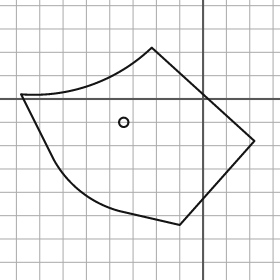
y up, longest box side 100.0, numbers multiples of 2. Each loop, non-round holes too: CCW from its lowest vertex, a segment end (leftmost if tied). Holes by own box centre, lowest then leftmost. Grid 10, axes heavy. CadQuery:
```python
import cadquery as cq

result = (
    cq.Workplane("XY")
    .moveTo(-10.0, -54.0)
    .lineTo(22.0, -18.0)
    .lineTo(-22.0, 22.0)
    .threePointArc((-48.0, 6.0), (-78.0, 2.0))
    .lineTo(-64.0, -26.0)
    .threePointArc((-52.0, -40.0), (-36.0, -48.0))
    .close()
    .moveTo(-34.0, -10.0)
    .circle(2.0)
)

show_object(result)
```